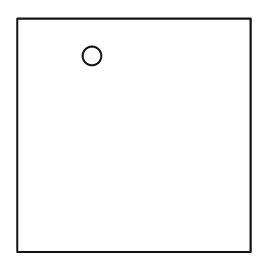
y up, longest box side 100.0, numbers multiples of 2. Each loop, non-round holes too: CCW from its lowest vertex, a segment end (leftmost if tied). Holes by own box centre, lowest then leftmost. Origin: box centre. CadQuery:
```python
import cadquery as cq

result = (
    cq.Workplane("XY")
    .moveTo(-50.0, -50.0)
    .lineTo(50.0, -50.0)
    .lineTo(50.0, 50.0)
    .lineTo(-50.0, 50.0)
    .close()
    .moveTo(-18.0, 34.0)
    .circle(4.0)
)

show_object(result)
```